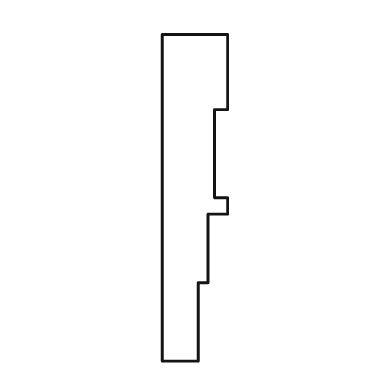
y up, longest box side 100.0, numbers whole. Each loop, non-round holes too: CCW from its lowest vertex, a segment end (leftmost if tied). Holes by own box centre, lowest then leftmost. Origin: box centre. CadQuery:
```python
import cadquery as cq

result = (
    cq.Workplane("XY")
    .moveTo(-10.0, -50.0)
    .lineTo(1.0, -50.0)
    .lineTo(1.0, -26.0)
    .lineTo(4.0, -26.0)
    .lineTo(4.0, -5.0)
    .lineTo(10.0, -5.0)
    .lineTo(10.0, 0.0)
    .lineTo(6.0, 0.0)
    .lineTo(6.0, 27.0)
    .lineTo(10.0, 27.0)
    .lineTo(10.0, 50.0)
    .lineTo(-10.0, 50.0)
    .close()
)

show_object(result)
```